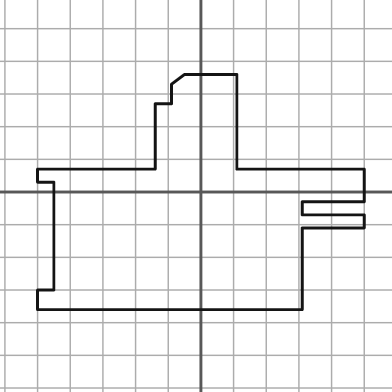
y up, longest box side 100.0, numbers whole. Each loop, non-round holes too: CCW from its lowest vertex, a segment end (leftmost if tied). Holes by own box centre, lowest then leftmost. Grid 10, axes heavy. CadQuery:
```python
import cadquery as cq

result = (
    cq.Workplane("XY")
    .moveTo(-50.0, -36.0)
    .lineTo(31.0, -36.0)
    .lineTo(31.0, -11.0)
    .lineTo(50.0, -11.0)
    .lineTo(50.0, -7.0)
    .lineTo(31.0, -7.0)
    .lineTo(31.0, -3.0)
    .lineTo(50.0, -3.0)
    .lineTo(50.0, 7.0)
    .lineTo(11.0, 7.0)
    .lineTo(11.0, 36.0)
    .lineTo(-5.0, 36.0)
    .lineTo(-9.0, 33.0)
    .lineTo(-9.0, 27.0)
    .lineTo(-14.0, 27.0)
    .lineTo(-14.0, 7.0)
    .lineTo(-50.0, 7.0)
    .lineTo(-50.0, 3.0)
    .lineTo(-45.0, 3.0)
    .lineTo(-45.0, -30.0)
    .lineTo(-50.0, -30.0)
    .close()
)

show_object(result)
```